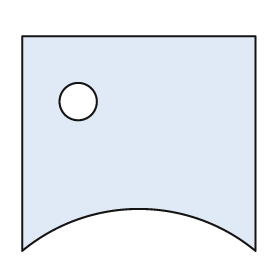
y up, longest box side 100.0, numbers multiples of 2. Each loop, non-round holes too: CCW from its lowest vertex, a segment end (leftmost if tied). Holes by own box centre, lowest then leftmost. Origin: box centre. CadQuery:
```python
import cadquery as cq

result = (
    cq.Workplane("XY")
    .moveTo(-50.0, -46.0)
    .threePointArc((0.0, -28.0), (50.0, -46.0))
    .lineTo(50.0, 46.0)
    .lineTo(-50.0, 46.0)
    .close()
    .moveTo(-26.0, 18.0)
    .circle(8.0)
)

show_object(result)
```